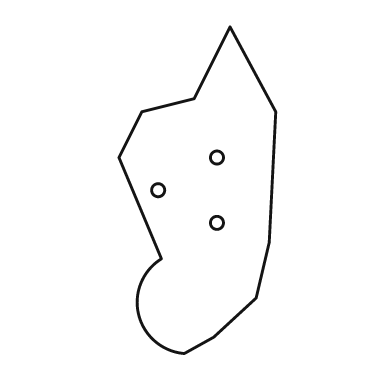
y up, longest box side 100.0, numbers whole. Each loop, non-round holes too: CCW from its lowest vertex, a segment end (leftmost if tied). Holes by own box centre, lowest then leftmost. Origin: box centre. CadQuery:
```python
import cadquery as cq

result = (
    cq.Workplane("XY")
    .moveTo(-4.0, -50.0)
    .lineTo(5.0, -45.0)
    .lineTo(18.0, -33.0)
    .lineTo(22.0, -16.0)
    .lineTo(24.0, 24.0)
    .lineTo(10.0, 50.0)
    .lineTo(-1.0, 28.0)
    .lineTo(-17.0, 24.0)
    .lineTo(-24.0, 10.0)
    .lineTo(-11.0, -21.0)
    .threePointArc((-18.0, -38.0), (-4.0, -50.0))
    .close()
    .moveTo(6.0, -10.0)
    .circle(2.0)
    .moveTo(-12.0, 0.0)
    .circle(2.0)
    .moveTo(6.0, 10.0)
    .circle(2.0)
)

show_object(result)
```